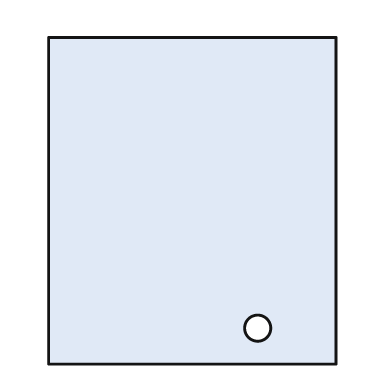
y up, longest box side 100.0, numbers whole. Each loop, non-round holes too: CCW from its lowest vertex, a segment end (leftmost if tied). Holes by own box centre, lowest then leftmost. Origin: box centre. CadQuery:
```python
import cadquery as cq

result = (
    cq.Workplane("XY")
    .moveTo(-44.0, -50.0)
    .lineTo(44.0, -50.0)
    .lineTo(44.0, 50.0)
    .lineTo(-44.0, 50.0)
    .close()
    .moveTo(20.0, -39.0)
    .circle(4.0)
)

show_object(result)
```